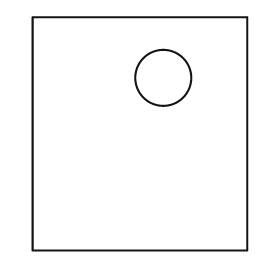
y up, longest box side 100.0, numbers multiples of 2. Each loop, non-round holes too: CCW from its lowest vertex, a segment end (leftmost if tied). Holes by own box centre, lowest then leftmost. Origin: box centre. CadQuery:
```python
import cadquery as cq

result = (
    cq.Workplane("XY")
    .moveTo(-46.0, -50.0)
    .lineTo(46.0, -50.0)
    .lineTo(46.0, 50.0)
    .lineTo(-46.0, 50.0)
    .close()
    .moveTo(10.0, 24.0)
    .circle(12.0)
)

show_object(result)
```